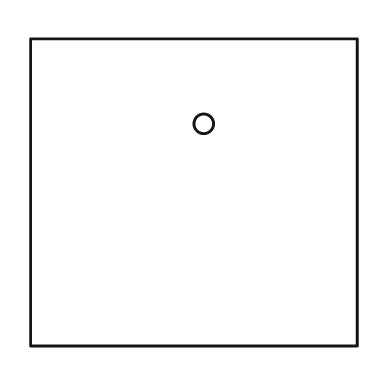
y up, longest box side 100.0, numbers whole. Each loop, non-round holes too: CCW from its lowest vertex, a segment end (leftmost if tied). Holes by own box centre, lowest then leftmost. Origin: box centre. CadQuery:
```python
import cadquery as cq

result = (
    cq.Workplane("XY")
    .moveTo(-50.0, -47.0)
    .lineTo(50.0, -47.0)
    .lineTo(50.0, 47.0)
    .lineTo(-50.0, 47.0)
    .close()
    .moveTo(3.0, 21.0)
    .circle(3.0)
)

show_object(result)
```